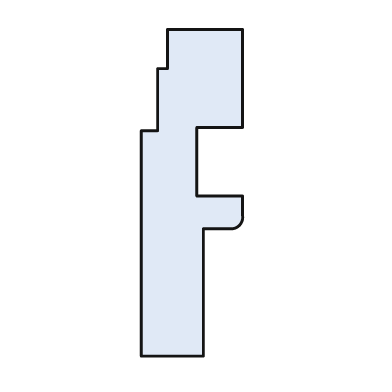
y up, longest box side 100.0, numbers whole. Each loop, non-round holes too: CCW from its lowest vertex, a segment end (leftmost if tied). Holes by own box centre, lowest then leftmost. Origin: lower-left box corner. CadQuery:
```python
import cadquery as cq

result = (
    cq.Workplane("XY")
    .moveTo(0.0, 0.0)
    .lineTo(19.0, 0.0)
    .lineTo(19.0, 39.0)
    .lineTo(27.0, 39.0)
    .threePointArc((30.0, 40.0), (31.0, 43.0))
    .lineTo(31.0, 49.0)
    .lineTo(17.0, 49.0)
    .lineTo(17.0, 70.0)
    .lineTo(31.0, 70.0)
    .lineTo(31.0, 100.0)
    .lineTo(8.0, 100.0)
    .lineTo(8.0, 88.0)
    .lineTo(5.0, 88.0)
    .lineTo(5.0, 69.0)
    .lineTo(0.0, 69.0)
    .close()
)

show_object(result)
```